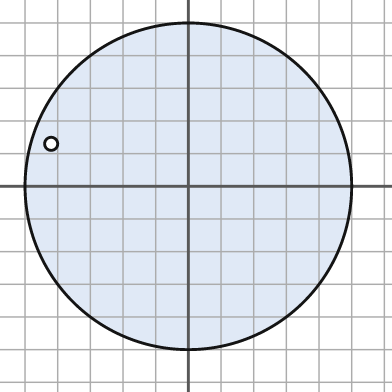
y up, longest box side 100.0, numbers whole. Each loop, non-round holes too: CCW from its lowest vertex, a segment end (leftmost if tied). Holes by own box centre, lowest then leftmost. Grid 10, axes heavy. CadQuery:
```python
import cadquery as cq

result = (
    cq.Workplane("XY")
    .moveTo(0.0, 0.0)
    .circle(50.0)
    .moveTo(-42.0, 13.0)
    .circle(2.0)
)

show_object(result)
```